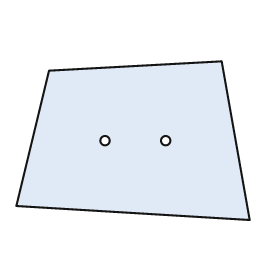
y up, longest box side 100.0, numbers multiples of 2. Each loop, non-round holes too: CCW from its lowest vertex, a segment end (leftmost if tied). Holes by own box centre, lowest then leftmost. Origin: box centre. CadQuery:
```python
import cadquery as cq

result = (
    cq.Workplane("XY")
    .moveTo(50.0, -34.0)
    .lineTo(38.0, 34.0)
    .lineTo(-36.0, 30.0)
    .lineTo(-50.0, -28.0)
    .close()
    .moveTo(-12.0, 0.0)
    .circle(2.0)
    .moveTo(14.0, 0.0)
    .circle(2.0)
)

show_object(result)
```